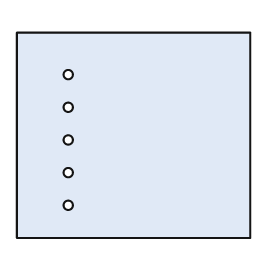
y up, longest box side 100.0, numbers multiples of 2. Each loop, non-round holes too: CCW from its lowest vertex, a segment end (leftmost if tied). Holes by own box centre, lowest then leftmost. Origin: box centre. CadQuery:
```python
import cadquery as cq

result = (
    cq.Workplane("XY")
    .moveTo(-50.0, -44.0)
    .lineTo(50.0, -44.0)
    .lineTo(50.0, 44.0)
    .lineTo(-50.0, 44.0)
    .close()
    .moveTo(-28.0, -30.0)
    .circle(2.0)
    .moveTo(-28.0, -16.0)
    .circle(2.0)
    .moveTo(-28.0, -2.0)
    .circle(2.0)
    .moveTo(-28.0, 12.0)
    .circle(2.0)
    .moveTo(-28.0, 26.0)
    .circle(2.0)
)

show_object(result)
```